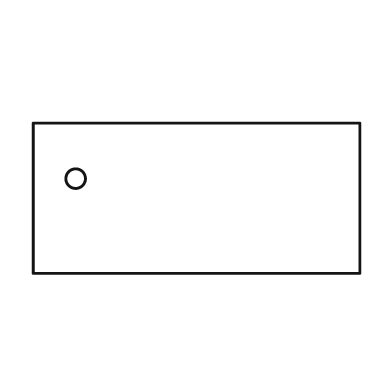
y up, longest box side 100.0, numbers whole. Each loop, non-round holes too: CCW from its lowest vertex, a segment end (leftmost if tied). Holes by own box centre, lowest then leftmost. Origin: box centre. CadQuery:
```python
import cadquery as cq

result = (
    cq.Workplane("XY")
    .moveTo(-50.0, -23.0)
    .lineTo(50.0, -23.0)
    .lineTo(50.0, 23.0)
    .lineTo(-50.0, 23.0)
    .close()
    .moveTo(-37.0, 6.0)
    .circle(3.0)
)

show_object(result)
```